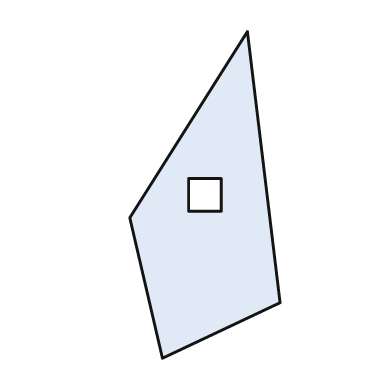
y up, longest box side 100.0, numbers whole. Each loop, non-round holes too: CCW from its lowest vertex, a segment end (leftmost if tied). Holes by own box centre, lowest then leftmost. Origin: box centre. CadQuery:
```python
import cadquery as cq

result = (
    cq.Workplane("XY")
    .moveTo(-13.0, -50.0)
    .lineTo(23.0, -33.0)
    .lineTo(13.0, 50.0)
    .lineTo(-23.0, -7.0)
    .close()
    .moveTo(-5.0, -5.0)
    .lineTo(5.0, -5.0)
    .lineTo(5.0, 5.0)
    .lineTo(-5.0, 5.0)
    .close()
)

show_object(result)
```